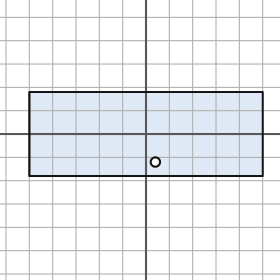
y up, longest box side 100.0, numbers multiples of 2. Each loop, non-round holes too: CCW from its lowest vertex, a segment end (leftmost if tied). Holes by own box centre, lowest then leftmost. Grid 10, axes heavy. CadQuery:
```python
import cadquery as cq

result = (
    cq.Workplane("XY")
    .moveTo(-50.0, -18.0)
    .lineTo(50.0, -18.0)
    .lineTo(50.0, 18.0)
    .lineTo(-50.0, 18.0)
    .close()
    .moveTo(4.0, -12.0)
    .circle(2.0)
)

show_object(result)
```